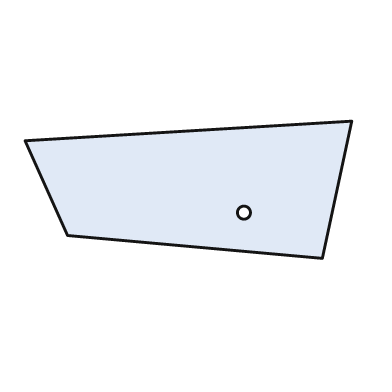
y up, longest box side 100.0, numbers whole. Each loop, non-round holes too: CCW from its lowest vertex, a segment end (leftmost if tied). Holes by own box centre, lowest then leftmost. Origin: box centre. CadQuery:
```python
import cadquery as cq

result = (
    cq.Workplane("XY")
    .moveTo(41.0, -21.0)
    .lineTo(50.0, 21.0)
    .lineTo(-50.0, 15.0)
    .lineTo(-37.0, -14.0)
    .close()
    .moveTo(17.0, -7.0)
    .circle(2.0)
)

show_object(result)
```